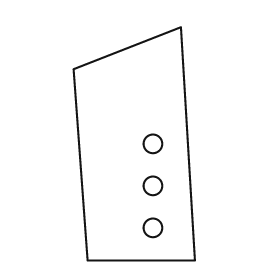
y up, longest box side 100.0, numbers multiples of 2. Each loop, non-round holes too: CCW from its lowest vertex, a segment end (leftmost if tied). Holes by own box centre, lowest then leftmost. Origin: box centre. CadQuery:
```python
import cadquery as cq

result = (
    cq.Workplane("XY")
    .moveTo(-20.0, -50.0)
    .lineTo(26.0, -50.0)
    .lineTo(20.0, 50.0)
    .lineTo(-26.0, 32.0)
    .close()
    .moveTo(8.0, -36.0)
    .circle(4.0)
    .moveTo(8.0, -18.0)
    .circle(4.0)
    .moveTo(8.0, 0.0)
    .circle(4.0)
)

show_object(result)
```